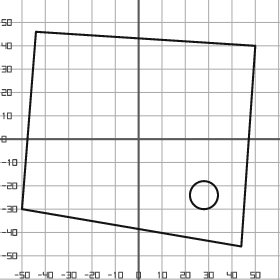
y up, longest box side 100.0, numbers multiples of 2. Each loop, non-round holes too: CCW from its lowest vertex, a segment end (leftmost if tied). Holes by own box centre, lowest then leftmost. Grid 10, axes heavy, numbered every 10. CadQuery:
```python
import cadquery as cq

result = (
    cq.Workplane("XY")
    .moveTo(44.0, -46.0)
    .lineTo(50.0, 40.0)
    .lineTo(-44.0, 46.0)
    .lineTo(-50.0, -30.0)
    .close()
    .moveTo(28.0, -24.0)
    .circle(6.0)
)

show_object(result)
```